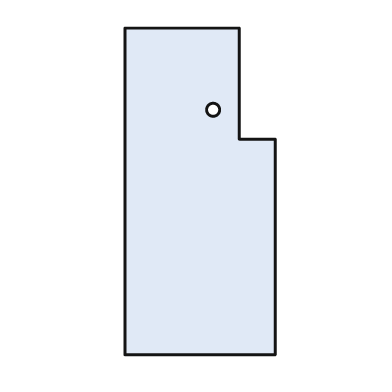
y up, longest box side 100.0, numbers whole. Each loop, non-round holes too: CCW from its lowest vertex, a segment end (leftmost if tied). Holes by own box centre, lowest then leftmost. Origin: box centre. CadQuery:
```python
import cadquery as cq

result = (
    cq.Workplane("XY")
    .moveTo(-23.0, -50.0)
    .lineTo(23.0, -50.0)
    .lineTo(23.0, 16.0)
    .lineTo(12.0, 16.0)
    .lineTo(12.0, 50.0)
    .lineTo(-23.0, 50.0)
    .close()
    .moveTo(4.0, 25.0)
    .circle(2.0)
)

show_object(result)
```